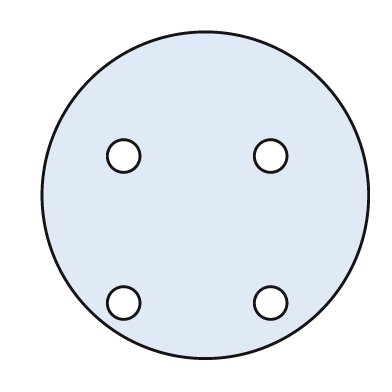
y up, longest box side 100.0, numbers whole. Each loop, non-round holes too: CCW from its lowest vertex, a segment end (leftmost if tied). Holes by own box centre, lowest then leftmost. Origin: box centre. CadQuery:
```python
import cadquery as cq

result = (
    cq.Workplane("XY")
    .moveTo(0.0, 0.0)
    .circle(50.0)
    .moveTo(-25.0, -33.0)
    .circle(5.0)
    .moveTo(20.0, -33.0)
    .circle(5.0)
    .moveTo(-25.0, 12.0)
    .circle(5.0)
    .moveTo(20.0, 12.0)
    .circle(5.0)
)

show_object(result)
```